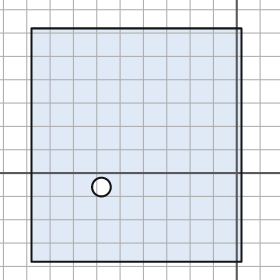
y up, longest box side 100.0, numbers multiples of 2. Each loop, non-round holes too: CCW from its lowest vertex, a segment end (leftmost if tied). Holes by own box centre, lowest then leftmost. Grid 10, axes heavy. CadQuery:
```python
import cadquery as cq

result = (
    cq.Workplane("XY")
    .moveTo(-88.0, -38.0)
    .lineTo(2.0, -38.0)
    .lineTo(2.0, 62.0)
    .lineTo(-88.0, 62.0)
    .close()
    .moveTo(-58.0, -6.0)
    .circle(4.0)
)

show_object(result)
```